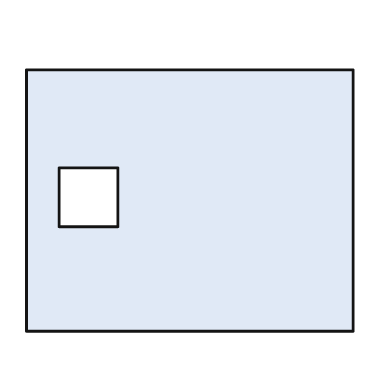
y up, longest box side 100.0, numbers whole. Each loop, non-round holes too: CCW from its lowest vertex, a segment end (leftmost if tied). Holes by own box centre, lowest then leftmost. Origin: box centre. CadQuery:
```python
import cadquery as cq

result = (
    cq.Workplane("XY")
    .moveTo(-50.0, -40.0)
    .lineTo(50.0, -40.0)
    .lineTo(50.0, 40.0)
    .lineTo(-50.0, 40.0)
    .close()
    .moveTo(-40.0, -8.0)
    .lineTo(-22.0, -8.0)
    .lineTo(-22.0, 10.0)
    .lineTo(-40.0, 10.0)
    .close()
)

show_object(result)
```